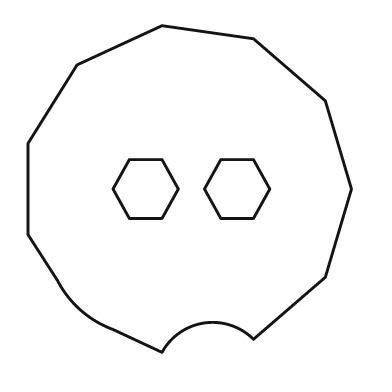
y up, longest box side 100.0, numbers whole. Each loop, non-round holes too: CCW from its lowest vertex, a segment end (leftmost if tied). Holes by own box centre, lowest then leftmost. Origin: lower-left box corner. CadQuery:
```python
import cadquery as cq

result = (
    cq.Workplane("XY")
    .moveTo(41.0, 0.0)
    .threePointArc((54.0, 9.0), (69.0, 4.0))
    .lineTo(91.0, 23.0)
    .lineTo(99.0, 50.0)
    .lineTo(91.0, 77.0)
    .lineTo(69.0, 96.0)
    .lineTo(41.0, 100.0)
    .lineTo(15.0, 88.0)
    .lineTo(0.0, 64.0)
    .lineTo(0.0, 36.0)
    .lineTo(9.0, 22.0)
    .threePointArc((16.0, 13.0), (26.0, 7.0))
    .close()
    .moveTo(31.0, 41.0)
    .lineTo(41.0, 41.0)
    .lineTo(46.0, 50.0)
    .lineTo(41.0, 59.0)
    .lineTo(31.0, 59.0)
    .lineTo(26.0, 50.0)
    .close()
    .moveTo(59.0, 41.0)
    .lineTo(69.0, 41.0)
    .lineTo(74.0, 50.0)
    .lineTo(69.0, 59.0)
    .lineTo(59.0, 59.0)
    .lineTo(54.0, 50.0)
    .close()
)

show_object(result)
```